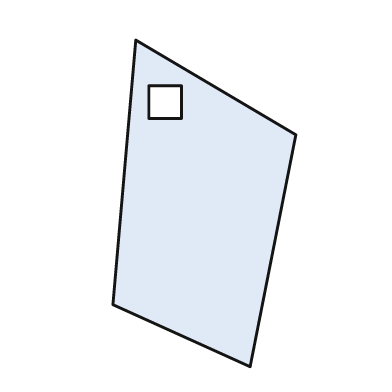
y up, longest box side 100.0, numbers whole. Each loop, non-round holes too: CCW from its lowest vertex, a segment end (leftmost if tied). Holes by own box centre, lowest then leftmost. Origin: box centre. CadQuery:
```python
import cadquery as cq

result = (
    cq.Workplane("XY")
    .moveTo(14.0, -50.0)
    .lineTo(28.0, 21.0)
    .lineTo(-21.0, 50.0)
    .lineTo(-28.0, -31.0)
    .close()
    .moveTo(-17.0, 26.0)
    .lineTo(-7.0, 26.0)
    .lineTo(-7.0, 36.0)
    .lineTo(-17.0, 36.0)
    .close()
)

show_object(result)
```